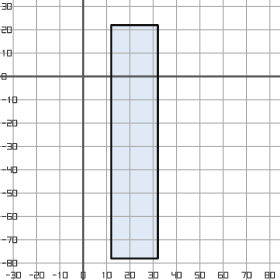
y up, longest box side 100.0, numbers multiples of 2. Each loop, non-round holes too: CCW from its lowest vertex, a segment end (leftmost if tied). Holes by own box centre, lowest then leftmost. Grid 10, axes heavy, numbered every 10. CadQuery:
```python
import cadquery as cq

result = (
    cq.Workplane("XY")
    .moveTo(12.0, -78.0)
    .lineTo(32.0, -78.0)
    .lineTo(32.0, 22.0)
    .lineTo(12.0, 22.0)
    .close()
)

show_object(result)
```